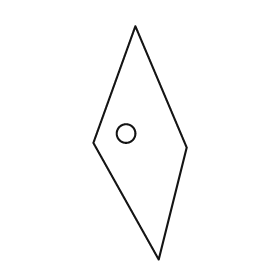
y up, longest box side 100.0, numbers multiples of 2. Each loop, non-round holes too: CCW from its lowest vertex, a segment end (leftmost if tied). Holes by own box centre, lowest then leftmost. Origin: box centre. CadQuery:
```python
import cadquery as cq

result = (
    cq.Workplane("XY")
    .moveTo(8.0, -50.0)
    .lineTo(20.0, -2.0)
    .lineTo(-2.0, 50.0)
    .lineTo(-20.0, 0.0)
    .close()
    .moveTo(-6.0, 4.0)
    .circle(4.0)
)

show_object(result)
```